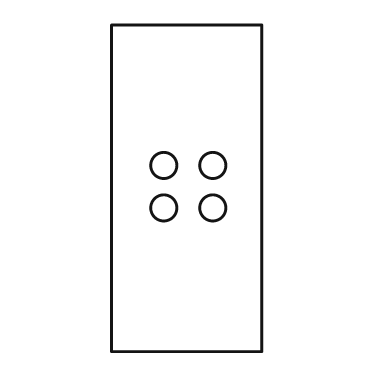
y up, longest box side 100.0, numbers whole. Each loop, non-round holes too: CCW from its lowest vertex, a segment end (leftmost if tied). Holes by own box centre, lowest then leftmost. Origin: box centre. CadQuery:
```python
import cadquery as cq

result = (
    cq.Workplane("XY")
    .moveTo(-23.0, -50.0)
    .lineTo(23.0, -50.0)
    .lineTo(23.0, 50.0)
    .lineTo(-23.0, 50.0)
    .close()
    .moveTo(-7.0, -6.0)
    .circle(4.0)
    .moveTo(8.0, -6.0)
    .circle(4.0)
    .moveTo(-7.0, 7.0)
    .circle(4.0)
    .moveTo(8.0, 7.0)
    .circle(4.0)
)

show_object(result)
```